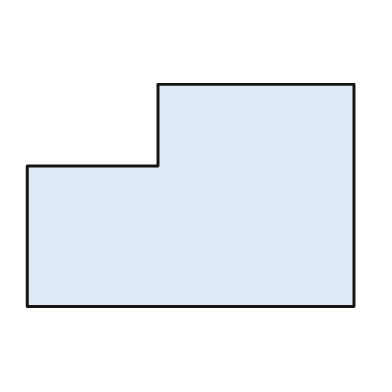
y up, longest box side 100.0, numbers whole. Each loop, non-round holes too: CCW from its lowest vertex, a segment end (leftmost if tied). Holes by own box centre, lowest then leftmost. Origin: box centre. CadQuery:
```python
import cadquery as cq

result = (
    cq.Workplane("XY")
    .moveTo(-50.0, -34.0)
    .lineTo(50.0, -34.0)
    .lineTo(50.0, 34.0)
    .lineTo(-10.0, 34.0)
    .lineTo(-10.0, 9.0)
    .lineTo(-50.0, 9.0)
    .close()
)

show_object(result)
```